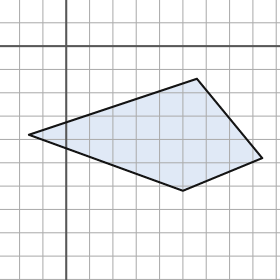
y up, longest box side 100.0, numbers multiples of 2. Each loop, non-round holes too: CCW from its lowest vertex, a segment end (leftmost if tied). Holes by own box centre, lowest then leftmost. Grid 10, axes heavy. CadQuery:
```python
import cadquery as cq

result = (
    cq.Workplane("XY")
    .moveTo(50.0, -62.0)
    .lineTo(84.0, -48.0)
    .lineTo(56.0, -14.0)
    .lineTo(-16.0, -38.0)
    .close()
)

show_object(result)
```